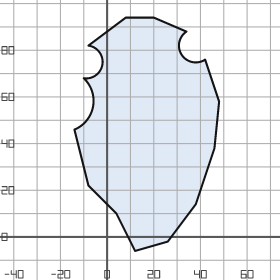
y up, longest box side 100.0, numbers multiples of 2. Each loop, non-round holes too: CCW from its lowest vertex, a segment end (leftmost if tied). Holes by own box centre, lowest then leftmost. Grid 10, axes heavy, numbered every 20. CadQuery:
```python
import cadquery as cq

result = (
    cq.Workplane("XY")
    .moveTo(12.0, -6.0)
    .lineTo(26.0, -2.0)
    .lineTo(38.0, 14.0)
    .lineTo(46.0, 38.0)
    .lineTo(48.0, 58.0)
    .lineTo(42.0, 76.0)
    .threePointArc((32.0, 78.0), (34.0, 88.0))
    .lineTo(20.0, 94.0)
    .lineTo(8.0, 94.0)
    .lineTo(-8.0, 82.0)
    .threePointArc((-2.0, 74.0), (-10.0, 68.0))
    .threePointArc((-6.0, 56.0), (-14.0, 46.0))
    .lineTo(-8.0, 22.0)
    .lineTo(4.0, 10.0)
    .close()
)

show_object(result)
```